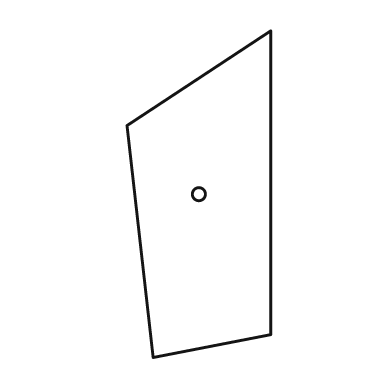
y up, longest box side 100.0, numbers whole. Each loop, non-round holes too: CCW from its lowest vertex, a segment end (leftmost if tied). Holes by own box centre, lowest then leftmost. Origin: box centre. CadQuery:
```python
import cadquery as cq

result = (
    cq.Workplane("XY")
    .moveTo(-14.0, -50.0)
    .lineTo(22.0, -43.0)
    .lineTo(22.0, 50.0)
    .lineTo(-22.0, 21.0)
    .close()
    .moveTo(0.0, 0.0)
    .circle(2.0)
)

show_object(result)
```